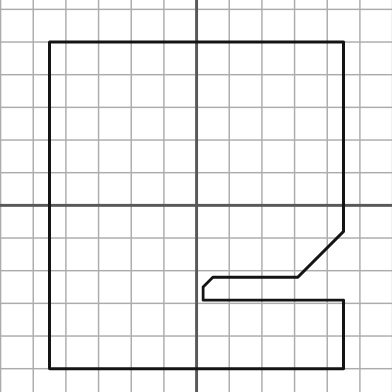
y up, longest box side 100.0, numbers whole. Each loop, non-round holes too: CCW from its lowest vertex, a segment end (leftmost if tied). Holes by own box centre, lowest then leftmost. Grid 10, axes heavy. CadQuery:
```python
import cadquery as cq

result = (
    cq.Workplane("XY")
    .moveTo(-45.0, -50.0)
    .lineTo(45.0, -50.0)
    .lineTo(45.0, -29.0)
    .lineTo(2.0, -29.0)
    .lineTo(2.0, -25.0)
    .lineTo(5.0, -22.0)
    .lineTo(31.0, -22.0)
    .lineTo(45.0, -8.0)
    .lineTo(45.0, 50.0)
    .lineTo(-45.0, 50.0)
    .close()
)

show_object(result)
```